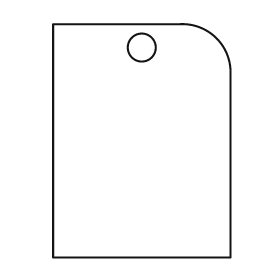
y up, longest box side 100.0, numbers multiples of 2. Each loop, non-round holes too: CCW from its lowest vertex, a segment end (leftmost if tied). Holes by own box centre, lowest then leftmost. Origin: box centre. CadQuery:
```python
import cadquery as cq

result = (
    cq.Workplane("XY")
    .moveTo(-38.0, -50.0)
    .lineTo(38.0, -50.0)
    .lineTo(38.0, 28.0)
    .threePointArc((32.0, 44.0), (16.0, 50.0))
    .lineTo(-38.0, 50.0)
    .close()
    .moveTo(0.0, 40.0)
    .circle(6.0)
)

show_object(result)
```